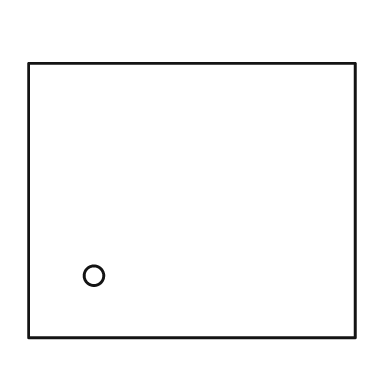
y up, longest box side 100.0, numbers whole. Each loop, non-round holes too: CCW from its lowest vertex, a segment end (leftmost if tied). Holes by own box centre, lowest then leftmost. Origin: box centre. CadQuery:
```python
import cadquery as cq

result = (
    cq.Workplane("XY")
    .moveTo(-50.0, -42.0)
    .lineTo(50.0, -42.0)
    .lineTo(50.0, 42.0)
    .lineTo(-50.0, 42.0)
    .close()
    .moveTo(-30.0, -23.0)
    .circle(3.0)
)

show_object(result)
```